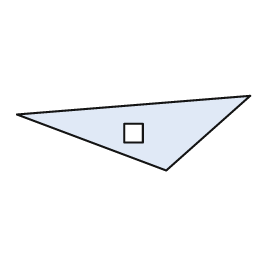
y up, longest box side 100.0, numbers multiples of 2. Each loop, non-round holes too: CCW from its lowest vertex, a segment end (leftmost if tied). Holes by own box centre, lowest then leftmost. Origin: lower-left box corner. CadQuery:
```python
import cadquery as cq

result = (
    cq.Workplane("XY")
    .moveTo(64.0, 0.0)
    .lineTo(100.0, 32.0)
    .lineTo(0.0, 24.0)
    .close()
    .moveTo(46.0, 12.0)
    .lineTo(54.0, 12.0)
    .lineTo(54.0, 20.0)
    .lineTo(46.0, 20.0)
    .close()
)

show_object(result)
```